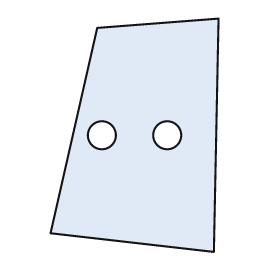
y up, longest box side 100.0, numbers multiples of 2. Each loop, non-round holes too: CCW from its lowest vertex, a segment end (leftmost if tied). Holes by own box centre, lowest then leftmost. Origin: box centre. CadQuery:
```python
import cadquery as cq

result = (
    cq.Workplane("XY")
    .moveTo(34.0, -50.0)
    .lineTo(36.0, 50.0)
    .lineTo(-16.0, 46.0)
    .lineTo(-36.0, -42.0)
    .close()
    .moveTo(-14.0, 0.0)
    .circle(6.0)
    .moveTo(14.0, 0.0)
    .circle(6.0)
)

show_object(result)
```